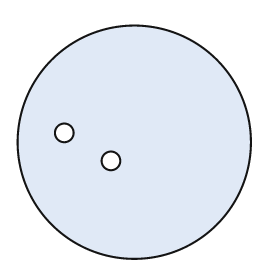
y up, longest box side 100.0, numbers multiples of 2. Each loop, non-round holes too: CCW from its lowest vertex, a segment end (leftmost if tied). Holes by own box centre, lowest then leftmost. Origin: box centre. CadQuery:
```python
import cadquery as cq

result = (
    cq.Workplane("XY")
    .moveTo(0.0, 0.0)
    .circle(50.0)
    .moveTo(-10.0, -8.0)
    .circle(4.0)
    .moveTo(-30.0, 4.0)
    .circle(4.0)
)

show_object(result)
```